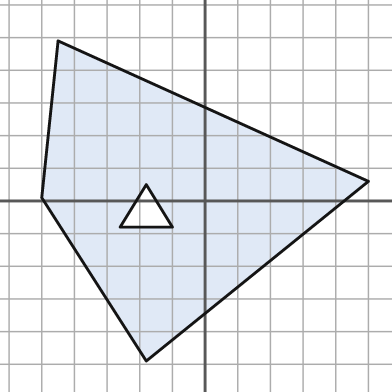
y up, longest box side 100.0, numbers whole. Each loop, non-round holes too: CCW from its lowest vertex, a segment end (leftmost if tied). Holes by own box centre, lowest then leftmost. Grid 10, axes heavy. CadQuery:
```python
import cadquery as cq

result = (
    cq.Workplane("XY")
    .moveTo(-18.0, -49.0)
    .lineTo(50.0, 6.0)
    .lineTo(-45.0, 49.0)
    .lineTo(-50.0, 1.0)
    .close()
    .moveTo(-26.0, -8.0)
    .lineTo(-10.0, -8.0)
    .lineTo(-18.0, 5.0)
    .close()
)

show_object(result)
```